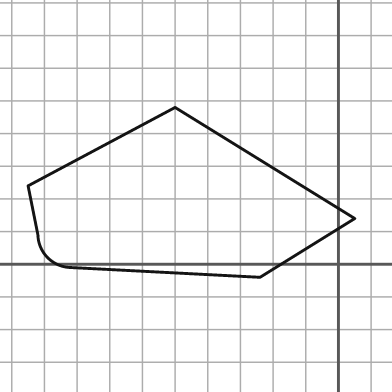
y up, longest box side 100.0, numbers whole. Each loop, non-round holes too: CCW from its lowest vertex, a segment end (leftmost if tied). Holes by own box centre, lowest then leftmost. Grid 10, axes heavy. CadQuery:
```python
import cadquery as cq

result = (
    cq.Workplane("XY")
    .moveTo(-24.0, -4.0)
    .lineTo(5.0, 14.0)
    .lineTo(-50.0, 48.0)
    .lineTo(-95.0, 24.0)
    .lineTo(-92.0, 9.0)
    .threePointArc((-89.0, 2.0), (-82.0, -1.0))
    .close()
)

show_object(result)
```